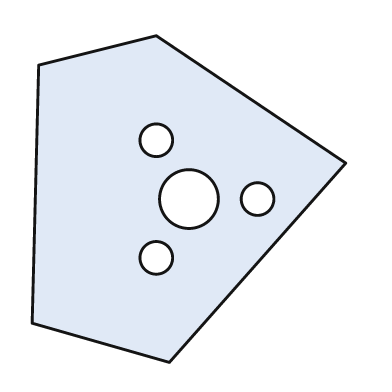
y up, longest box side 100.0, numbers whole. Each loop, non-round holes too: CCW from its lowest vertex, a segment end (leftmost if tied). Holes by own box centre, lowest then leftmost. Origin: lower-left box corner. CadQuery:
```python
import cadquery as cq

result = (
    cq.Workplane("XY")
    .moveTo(42.0, 0.0)
    .lineTo(96.0, 61.0)
    .lineTo(38.0, 100.0)
    .lineTo(2.0, 91.0)
    .lineTo(0.0, 12.0)
    .close()
    .moveTo(38.0, 32.0)
    .circle(5.0)
    .moveTo(48.0, 50.0)
    .circle(9.0)
    .moveTo(69.0, 50.0)
    .circle(5.0)
    .moveTo(38.0, 68.0)
    .circle(5.0)
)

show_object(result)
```